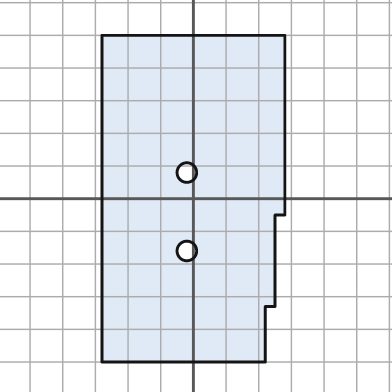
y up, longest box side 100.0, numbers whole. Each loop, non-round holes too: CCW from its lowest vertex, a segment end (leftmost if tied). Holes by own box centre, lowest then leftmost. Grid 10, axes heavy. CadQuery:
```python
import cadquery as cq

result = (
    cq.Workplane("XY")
    .moveTo(-28.0, -50.0)
    .lineTo(22.0, -50.0)
    .lineTo(22.0, -33.0)
    .lineTo(25.0, -33.0)
    .lineTo(25.0, -5.0)
    .lineTo(28.0, -5.0)
    .lineTo(28.0, 50.0)
    .lineTo(-28.0, 50.0)
    .close()
    .moveTo(-2.0, -16.0)
    .circle(3.0)
    .moveTo(-2.0, 8.0)
    .circle(3.0)
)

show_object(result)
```